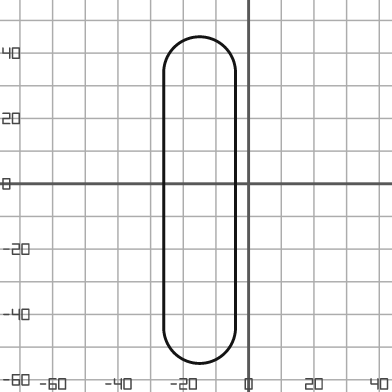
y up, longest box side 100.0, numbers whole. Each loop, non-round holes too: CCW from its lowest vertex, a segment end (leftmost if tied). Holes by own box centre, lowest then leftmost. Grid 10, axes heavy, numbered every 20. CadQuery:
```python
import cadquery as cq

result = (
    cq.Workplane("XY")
    .moveTo(-26.0, -44.0)
    .threePointArc((-15.0, -55.0), (-4.0, -44.0))
    .lineTo(-4.0, 34.0)
    .threePointArc((-15.0, 45.0), (-26.0, 34.0))
    .close()
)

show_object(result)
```